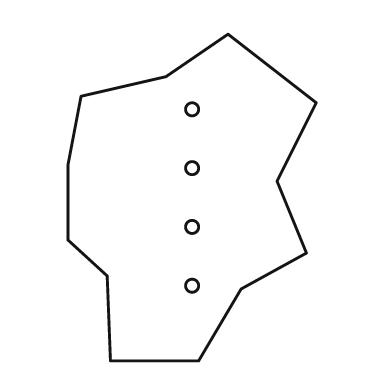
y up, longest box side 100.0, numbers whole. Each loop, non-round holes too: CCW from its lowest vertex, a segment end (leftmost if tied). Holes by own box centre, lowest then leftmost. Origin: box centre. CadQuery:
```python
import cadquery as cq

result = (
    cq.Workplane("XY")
    .moveTo(-25.0, -50.0)
    .lineTo(2.0, -50.0)
    .lineTo(15.0, -28.0)
    .lineTo(35.0, -17.0)
    .lineTo(26.0, 5.0)
    .lineTo(38.0, 29.0)
    .lineTo(11.0, 50.0)
    .lineTo(-8.0, 37.0)
    .lineTo(-34.0, 31.0)
    .lineTo(-38.0, 10.0)
    .lineTo(-38.0, -13.0)
    .lineTo(-26.0, -24.0)
    .close()
    .moveTo(0.0, -27.0)
    .circle(2.0)
    .moveTo(0.0, -9.0)
    .circle(2.0)
    .moveTo(0.0, 9.0)
    .circle(2.0)
    .moveTo(0.0, 27.0)
    .circle(2.0)
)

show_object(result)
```